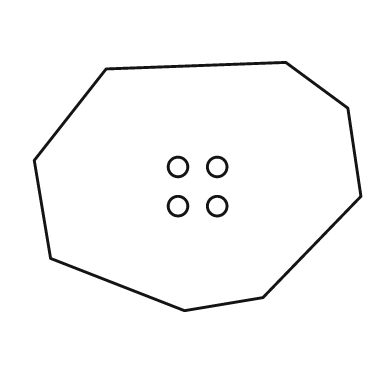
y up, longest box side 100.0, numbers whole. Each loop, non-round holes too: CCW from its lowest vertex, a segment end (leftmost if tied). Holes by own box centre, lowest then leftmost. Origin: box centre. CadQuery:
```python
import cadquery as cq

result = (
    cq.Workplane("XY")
    .moveTo(-4.0, -38.0)
    .lineTo(20.0, -34.0)
    .lineTo(50.0, -3.0)
    .lineTo(46.0, 24.0)
    .lineTo(27.0, 38.0)
    .lineTo(-28.0, 36.0)
    .lineTo(-50.0, 8.0)
    .lineTo(-45.0, -22.0)
    .close()
    .moveTo(-6.0, -6.0)
    .circle(3.0)
    .moveTo(6.0, -6.0)
    .circle(3.0)
    .moveTo(-6.0, 6.0)
    .circle(3.0)
    .moveTo(6.0, 6.0)
    .circle(3.0)
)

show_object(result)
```